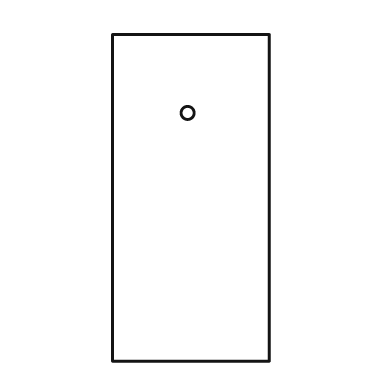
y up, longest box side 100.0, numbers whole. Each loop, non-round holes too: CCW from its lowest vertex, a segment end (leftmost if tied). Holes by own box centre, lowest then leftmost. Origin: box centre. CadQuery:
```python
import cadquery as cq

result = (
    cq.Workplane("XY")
    .moveTo(-24.0, -50.0)
    .lineTo(24.0, -50.0)
    .lineTo(24.0, 50.0)
    .lineTo(-24.0, 50.0)
    .close()
    .moveTo(-1.0, 26.0)
    .circle(2.0)
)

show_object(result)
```